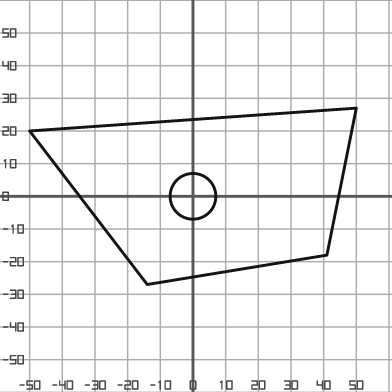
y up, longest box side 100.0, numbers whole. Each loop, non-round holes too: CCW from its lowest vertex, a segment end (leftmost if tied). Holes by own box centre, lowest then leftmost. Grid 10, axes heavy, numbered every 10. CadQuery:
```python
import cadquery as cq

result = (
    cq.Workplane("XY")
    .moveTo(-14.0, -27.0)
    .lineTo(41.0, -18.0)
    .lineTo(50.0, 27.0)
    .lineTo(-50.0, 20.0)
    .close()
    .moveTo(0.0, 0.0)
    .circle(7.0)
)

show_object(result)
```